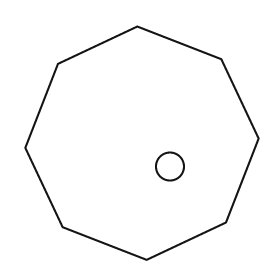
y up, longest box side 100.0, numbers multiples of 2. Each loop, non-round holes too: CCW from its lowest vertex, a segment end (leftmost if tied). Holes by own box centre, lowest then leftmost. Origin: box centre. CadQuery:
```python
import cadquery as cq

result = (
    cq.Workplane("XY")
    .moveTo(2.0, -50.0)
    .lineTo(36.0, -34.0)
    .lineTo(50.0, 2.0)
    .lineTo(34.0, 36.0)
    .lineTo(-2.0, 50.0)
    .lineTo(-36.0, 34.0)
    .lineTo(-50.0, -2.0)
    .lineTo(-34.0, -36.0)
    .close()
    .moveTo(12.0, -10.0)
    .circle(6.0)
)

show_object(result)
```